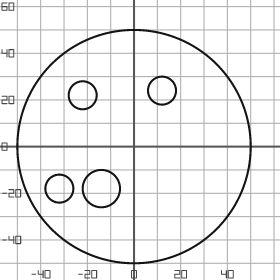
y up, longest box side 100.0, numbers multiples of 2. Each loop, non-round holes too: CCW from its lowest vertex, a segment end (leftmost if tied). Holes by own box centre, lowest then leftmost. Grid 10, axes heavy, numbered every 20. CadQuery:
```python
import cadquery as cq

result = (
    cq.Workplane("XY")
    .moveTo(0.0, 0.0)
    .circle(50.0)
    .moveTo(-32.0, -18.0)
    .circle(6.0)
    .moveTo(-14.0, -18.0)
    .circle(8.0)
    .moveTo(-22.0, 22.0)
    .circle(6.0)
    .moveTo(12.0, 24.0)
    .circle(6.0)
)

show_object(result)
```